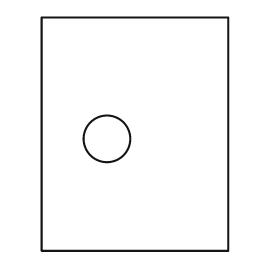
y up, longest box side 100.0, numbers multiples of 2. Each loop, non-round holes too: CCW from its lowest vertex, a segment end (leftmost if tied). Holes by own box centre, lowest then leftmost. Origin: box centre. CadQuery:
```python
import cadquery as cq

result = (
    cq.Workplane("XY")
    .moveTo(-40.0, -50.0)
    .lineTo(40.0, -50.0)
    .lineTo(40.0, 50.0)
    .lineTo(-40.0, 50.0)
    .close()
    .moveTo(-12.0, -2.0)
    .circle(10.0)
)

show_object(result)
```